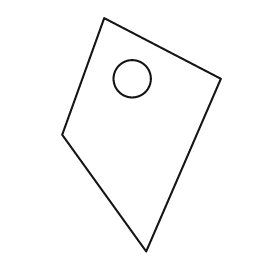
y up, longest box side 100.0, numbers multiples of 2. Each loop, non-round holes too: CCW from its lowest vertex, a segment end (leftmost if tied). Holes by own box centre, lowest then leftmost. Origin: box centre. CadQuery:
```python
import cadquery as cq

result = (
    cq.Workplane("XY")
    .moveTo(2.0, -50.0)
    .lineTo(34.0, 24.0)
    .lineTo(-16.0, 50.0)
    .lineTo(-34.0, 0.0)
    .close()
    .moveTo(-4.0, 24.0)
    .circle(8.0)
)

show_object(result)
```